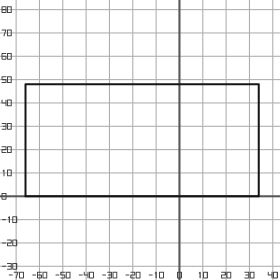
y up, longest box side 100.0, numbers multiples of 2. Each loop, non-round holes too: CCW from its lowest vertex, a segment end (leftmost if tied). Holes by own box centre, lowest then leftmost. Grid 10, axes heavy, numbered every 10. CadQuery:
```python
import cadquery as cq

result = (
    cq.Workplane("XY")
    .moveTo(-66.0, 0.0)
    .lineTo(34.0, 0.0)
    .lineTo(34.0, 48.0)
    .lineTo(-66.0, 48.0)
    .close()
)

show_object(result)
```